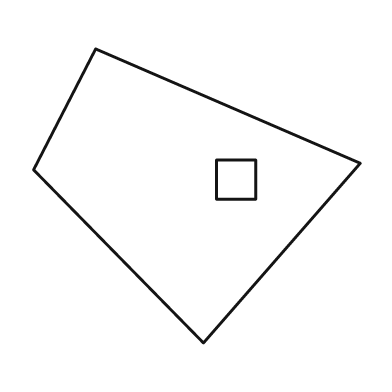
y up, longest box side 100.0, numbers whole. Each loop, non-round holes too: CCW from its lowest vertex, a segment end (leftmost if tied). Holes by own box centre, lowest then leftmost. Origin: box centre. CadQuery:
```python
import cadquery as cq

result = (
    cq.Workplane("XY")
    .moveTo(2.0, -45.0)
    .lineTo(50.0, 10.0)
    .lineTo(-31.0, 45.0)
    .lineTo(-50.0, 8.0)
    .close()
    .moveTo(6.0, -1.0)
    .lineTo(18.0, -1.0)
    .lineTo(18.0, 11.0)
    .lineTo(6.0, 11.0)
    .close()
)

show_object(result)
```